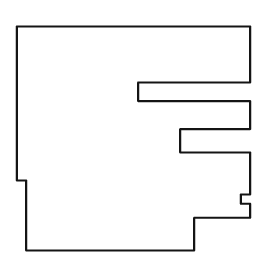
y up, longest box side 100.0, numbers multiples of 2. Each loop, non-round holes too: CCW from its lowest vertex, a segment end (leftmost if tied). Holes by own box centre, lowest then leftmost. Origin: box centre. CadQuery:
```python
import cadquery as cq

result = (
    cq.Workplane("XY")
    .moveTo(-46.0, -48.0)
    .lineTo(26.0, -48.0)
    .lineTo(26.0, -34.0)
    .lineTo(50.0, -34.0)
    .lineTo(50.0, -28.0)
    .lineTo(46.0, -28.0)
    .lineTo(46.0, -24.0)
    .lineTo(50.0, -24.0)
    .lineTo(50.0, -6.0)
    .lineTo(20.0, -6.0)
    .lineTo(20.0, 4.0)
    .lineTo(50.0, 4.0)
    .lineTo(50.0, 16.0)
    .lineTo(2.0, 16.0)
    .lineTo(2.0, 24.0)
    .lineTo(50.0, 24.0)
    .lineTo(50.0, 48.0)
    .lineTo(-50.0, 48.0)
    .lineTo(-50.0, -18.0)
    .lineTo(-46.0, -18.0)
    .close()
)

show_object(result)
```